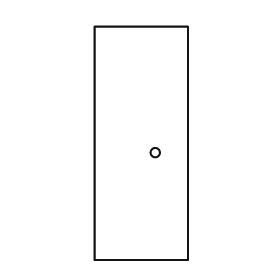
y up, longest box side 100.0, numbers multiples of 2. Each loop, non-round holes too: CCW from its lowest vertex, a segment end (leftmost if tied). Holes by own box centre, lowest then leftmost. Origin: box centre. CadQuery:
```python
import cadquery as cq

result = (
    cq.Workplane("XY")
    .moveTo(-20.0, -50.0)
    .lineTo(20.0, -50.0)
    .lineTo(20.0, 50.0)
    .lineTo(-20.0, 50.0)
    .close()
    .moveTo(6.0, -4.0)
    .circle(2.0)
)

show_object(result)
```